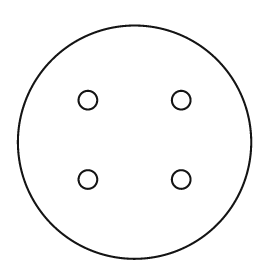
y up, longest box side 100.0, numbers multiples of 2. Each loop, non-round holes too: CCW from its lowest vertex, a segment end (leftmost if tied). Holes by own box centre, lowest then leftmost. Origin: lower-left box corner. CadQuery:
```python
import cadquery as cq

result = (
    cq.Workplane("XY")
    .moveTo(50.0, 50.0)
    .circle(50.0)
    .moveTo(30.0, 34.0)
    .circle(4.0)
    .moveTo(70.0, 34.0)
    .circle(4.0)
    .moveTo(30.0, 68.0)
    .circle(4.0)
    .moveTo(70.0, 68.0)
    .circle(4.0)
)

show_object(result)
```